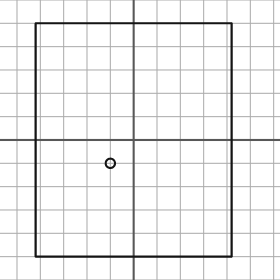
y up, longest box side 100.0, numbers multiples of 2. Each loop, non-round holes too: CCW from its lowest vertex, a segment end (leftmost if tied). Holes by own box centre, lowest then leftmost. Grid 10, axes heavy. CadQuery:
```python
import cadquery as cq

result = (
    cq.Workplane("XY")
    .moveTo(-42.0, -50.0)
    .lineTo(42.0, -50.0)
    .lineTo(42.0, 50.0)
    .lineTo(-42.0, 50.0)
    .close()
    .moveTo(-10.0, -10.0)
    .circle(2.0)
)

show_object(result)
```